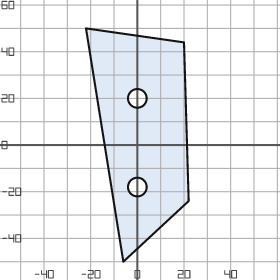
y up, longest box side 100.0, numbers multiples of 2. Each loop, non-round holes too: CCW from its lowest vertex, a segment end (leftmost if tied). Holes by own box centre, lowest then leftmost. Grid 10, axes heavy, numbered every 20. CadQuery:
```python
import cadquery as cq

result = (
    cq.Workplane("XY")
    .moveTo(-6.0, -50.0)
    .lineTo(22.0, -24.0)
    .lineTo(20.0, 44.0)
    .lineTo(-22.0, 50.0)
    .close()
    .moveTo(0.0, -18.0)
    .circle(4.0)
    .moveTo(0.0, 20.0)
    .circle(4.0)
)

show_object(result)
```